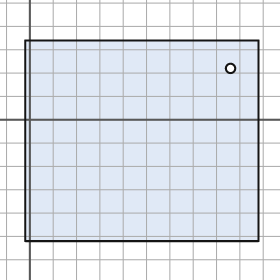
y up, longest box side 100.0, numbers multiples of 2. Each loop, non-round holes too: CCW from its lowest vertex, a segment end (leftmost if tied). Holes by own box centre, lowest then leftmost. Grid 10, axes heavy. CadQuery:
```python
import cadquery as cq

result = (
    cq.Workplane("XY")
    .moveTo(-2.0, -52.0)
    .lineTo(98.0, -52.0)
    .lineTo(98.0, 34.0)
    .lineTo(-2.0, 34.0)
    .close()
    .moveTo(86.0, 22.0)
    .circle(2.0)
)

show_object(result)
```